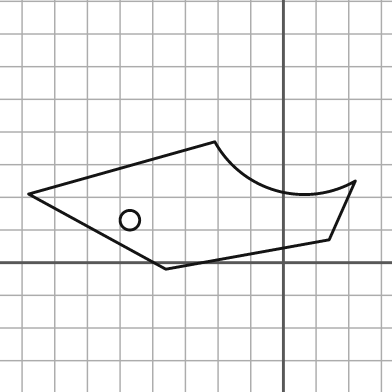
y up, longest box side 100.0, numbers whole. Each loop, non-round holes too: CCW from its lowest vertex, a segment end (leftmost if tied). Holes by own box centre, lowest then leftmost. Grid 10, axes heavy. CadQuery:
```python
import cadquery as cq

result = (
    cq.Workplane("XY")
    .moveTo(-36.0, -2.0)
    .lineTo(14.0, 7.0)
    .lineTo(22.0, 25.0)
    .threePointArc((-2.0, 22.0), (-21.0, 37.0))
    .lineTo(-78.0, 21.0)
    .close()
    .moveTo(-47.0, 13.0)
    .circle(3.0)
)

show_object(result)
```